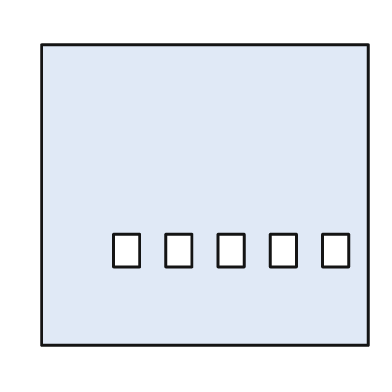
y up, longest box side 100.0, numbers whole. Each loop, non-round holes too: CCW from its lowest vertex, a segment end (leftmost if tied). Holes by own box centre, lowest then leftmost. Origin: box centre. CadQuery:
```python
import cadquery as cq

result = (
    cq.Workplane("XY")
    .moveTo(-50.0, -46.0)
    .lineTo(50.0, -46.0)
    .lineTo(50.0, 46.0)
    .lineTo(-50.0, 46.0)
    .close()
    .moveTo(-28.0, -22.0)
    .lineTo(-20.0, -22.0)
    .lineTo(-20.0, -12.0)
    .lineTo(-28.0, -12.0)
    .close()
    .moveTo(-12.0, -22.0)
    .lineTo(-4.0, -22.0)
    .lineTo(-4.0, -12.0)
    .lineTo(-12.0, -12.0)
    .close()
    .moveTo(4.0, -22.0)
    .lineTo(12.0, -22.0)
    .lineTo(12.0, -12.0)
    .lineTo(4.0, -12.0)
    .close()
    .moveTo(20.0, -22.0)
    .lineTo(28.0, -22.0)
    .lineTo(28.0, -12.0)
    .lineTo(20.0, -12.0)
    .close()
    .moveTo(36.0, -22.0)
    .lineTo(44.0, -22.0)
    .lineTo(44.0, -12.0)
    .lineTo(36.0, -12.0)
    .close()
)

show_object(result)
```